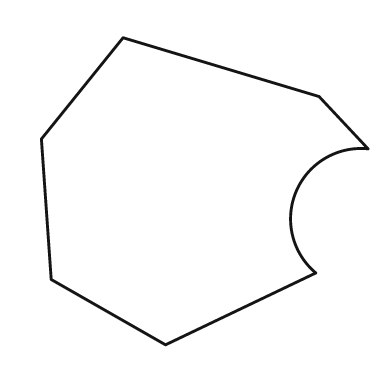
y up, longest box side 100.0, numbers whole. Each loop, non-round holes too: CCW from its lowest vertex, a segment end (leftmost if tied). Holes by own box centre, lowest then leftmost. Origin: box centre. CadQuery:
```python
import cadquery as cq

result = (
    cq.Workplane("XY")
    .moveTo(-12.0, -47.0)
    .lineTo(34.0, -25.0)
    .threePointArc((28.0, 0.0), (50.0, 13.0))
    .lineTo(35.0, 29.0)
    .lineTo(-25.0, 47.0)
    .lineTo(-50.0, 16.0)
    .lineTo(-47.0, -27.0)
    .close()
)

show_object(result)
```